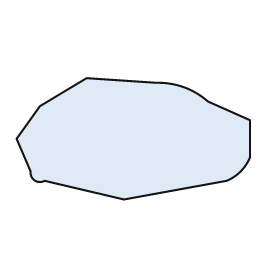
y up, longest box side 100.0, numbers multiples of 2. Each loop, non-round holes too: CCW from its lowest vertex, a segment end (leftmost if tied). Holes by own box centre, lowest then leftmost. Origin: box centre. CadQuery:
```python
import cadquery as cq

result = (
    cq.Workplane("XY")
    .moveTo(-4.0, -26.0)
    .lineTo(40.0, -18.0)
    .threePointArc((46.0, -14.0), (50.0, -8.0))
    .lineTo(50.0, 8.0)
    .lineTo(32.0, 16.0)
    .threePointArc((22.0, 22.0), (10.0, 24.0))
    .lineTo(-20.0, 26.0)
    .lineTo(-40.0, 14.0)
    .lineTo(-50.0, 0.0)
    .lineTo(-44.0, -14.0)
    .threePointArc((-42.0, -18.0), (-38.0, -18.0))
    .close()
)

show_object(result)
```